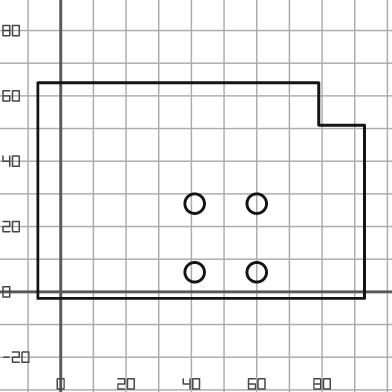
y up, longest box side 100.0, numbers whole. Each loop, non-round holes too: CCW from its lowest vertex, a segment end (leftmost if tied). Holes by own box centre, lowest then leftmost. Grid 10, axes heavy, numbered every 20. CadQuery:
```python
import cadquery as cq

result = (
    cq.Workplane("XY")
    .moveTo(-7.0, -2.0)
    .lineTo(93.0, -2.0)
    .lineTo(93.0, 51.0)
    .lineTo(79.0, 51.0)
    .lineTo(79.0, 64.0)
    .lineTo(-7.0, 64.0)
    .close()
    .moveTo(41.0, 6.0)
    .circle(3.0)
    .moveTo(60.0, 6.0)
    .circle(3.0)
    .moveTo(41.0, 27.0)
    .circle(3.0)
    .moveTo(60.0, 27.0)
    .circle(3.0)
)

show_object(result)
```